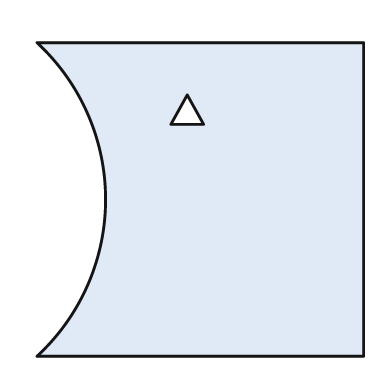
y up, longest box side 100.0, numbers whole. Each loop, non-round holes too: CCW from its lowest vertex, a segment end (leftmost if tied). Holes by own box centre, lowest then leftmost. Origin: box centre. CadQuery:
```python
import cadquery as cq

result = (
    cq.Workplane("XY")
    .moveTo(-50.0, -48.0)
    .lineTo(50.0, -48.0)
    .lineTo(50.0, 48.0)
    .lineTo(-50.0, 48.0)
    .threePointArc((-29.0, 0.0), (-50.0, -48.0))
    .close()
    .moveTo(-9.0, 23.0)
    .lineTo(1.0, 23.0)
    .lineTo(-4.0, 32.0)
    .close()
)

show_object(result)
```